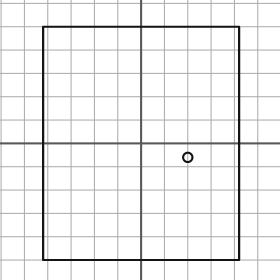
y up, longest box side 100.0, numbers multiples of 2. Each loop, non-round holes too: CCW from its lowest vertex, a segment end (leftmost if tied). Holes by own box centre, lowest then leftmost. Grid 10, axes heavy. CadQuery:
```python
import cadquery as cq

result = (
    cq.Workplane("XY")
    .moveTo(-42.0, -50.0)
    .lineTo(42.0, -50.0)
    .lineTo(42.0, 50.0)
    .lineTo(-42.0, 50.0)
    .close()
    .moveTo(20.0, -6.0)
    .circle(2.0)
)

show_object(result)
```